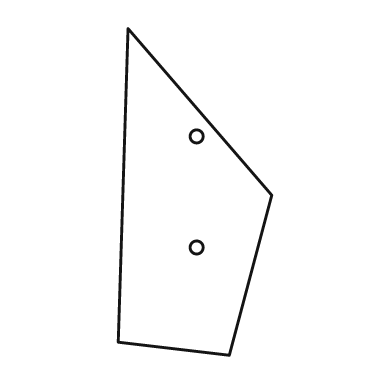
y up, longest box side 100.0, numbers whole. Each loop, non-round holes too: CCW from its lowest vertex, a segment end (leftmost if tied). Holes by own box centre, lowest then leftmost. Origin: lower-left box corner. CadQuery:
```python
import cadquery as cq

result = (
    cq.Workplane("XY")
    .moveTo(34.0, 0.0)
    .lineTo(47.0, 49.0)
    .lineTo(3.0, 100.0)
    .lineTo(0.0, 4.0)
    .close()
    .moveTo(24.0, 33.0)
    .circle(2.0)
    .moveTo(24.0, 67.0)
    .circle(2.0)
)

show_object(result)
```